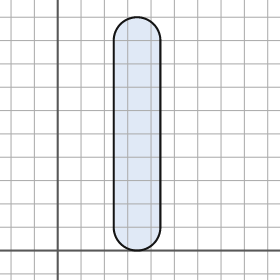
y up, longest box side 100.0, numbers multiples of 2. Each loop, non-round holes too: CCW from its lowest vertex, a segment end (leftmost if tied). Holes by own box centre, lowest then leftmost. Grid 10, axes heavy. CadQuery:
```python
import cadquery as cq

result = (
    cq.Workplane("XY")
    .moveTo(24.0, 10.0)
    .threePointArc((34.0, 0.0), (44.0, 10.0))
    .lineTo(44.0, 90.0)
    .threePointArc((34.0, 100.0), (24.0, 90.0))
    .close()
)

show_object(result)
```